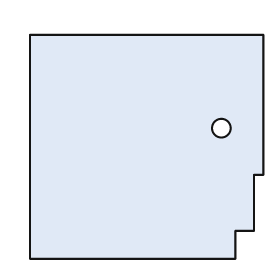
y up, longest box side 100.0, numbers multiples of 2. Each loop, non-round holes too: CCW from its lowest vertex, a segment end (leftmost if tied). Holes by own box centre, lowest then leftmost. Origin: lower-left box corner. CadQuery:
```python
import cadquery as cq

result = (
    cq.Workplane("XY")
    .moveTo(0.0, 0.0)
    .lineTo(88.0, 0.0)
    .lineTo(88.0, 12.0)
    .lineTo(96.0, 12.0)
    .lineTo(96.0, 36.0)
    .lineTo(100.0, 36.0)
    .lineTo(100.0, 96.0)
    .lineTo(0.0, 96.0)
    .close()
    .moveTo(82.0, 56.0)
    .circle(4.0)
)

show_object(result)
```